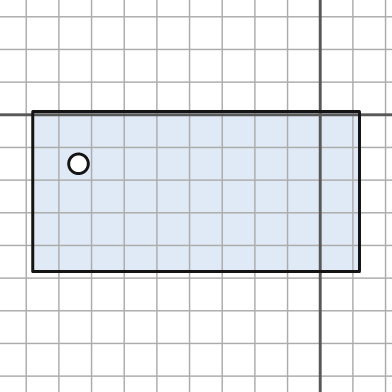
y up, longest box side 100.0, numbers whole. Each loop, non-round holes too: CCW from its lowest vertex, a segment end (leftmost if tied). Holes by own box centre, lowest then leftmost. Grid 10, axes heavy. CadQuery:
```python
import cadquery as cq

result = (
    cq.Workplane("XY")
    .moveTo(-88.0, -48.0)
    .lineTo(12.0, -48.0)
    .lineTo(12.0, 1.0)
    .lineTo(-88.0, 1.0)
    .close()
    .moveTo(-74.0, -15.0)
    .circle(3.0)
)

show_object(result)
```